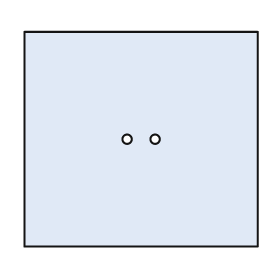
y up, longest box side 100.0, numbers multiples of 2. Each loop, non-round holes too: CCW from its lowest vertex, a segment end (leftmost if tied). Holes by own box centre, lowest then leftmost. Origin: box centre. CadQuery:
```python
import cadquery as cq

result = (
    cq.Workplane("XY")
    .moveTo(-50.0, -46.0)
    .lineTo(50.0, -46.0)
    .lineTo(50.0, 46.0)
    .lineTo(-50.0, 46.0)
    .close()
    .moveTo(-6.0, 0.0)
    .circle(2.0)
    .moveTo(6.0, 0.0)
    .circle(2.0)
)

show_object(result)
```